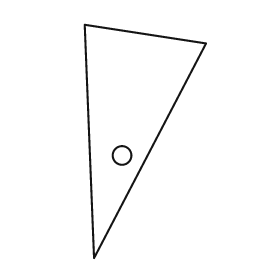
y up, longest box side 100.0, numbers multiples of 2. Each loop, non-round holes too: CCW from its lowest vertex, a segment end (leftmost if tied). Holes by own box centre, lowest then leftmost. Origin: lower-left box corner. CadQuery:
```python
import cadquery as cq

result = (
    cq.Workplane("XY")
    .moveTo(4.0, 0.0)
    .lineTo(52.0, 92.0)
    .lineTo(0.0, 100.0)
    .close()
    .moveTo(16.0, 44.0)
    .circle(4.0)
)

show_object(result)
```